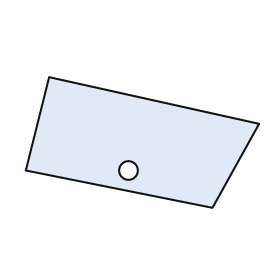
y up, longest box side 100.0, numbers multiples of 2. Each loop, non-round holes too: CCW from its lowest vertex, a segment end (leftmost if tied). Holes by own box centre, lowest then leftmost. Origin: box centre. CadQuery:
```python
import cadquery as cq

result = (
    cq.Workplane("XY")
    .moveTo(30.0, -28.0)
    .lineTo(50.0, 8.0)
    .lineTo(-40.0, 28.0)
    .lineTo(-50.0, -12.0)
    .close()
    .moveTo(-6.0, -12.0)
    .circle(4.0)
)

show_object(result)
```